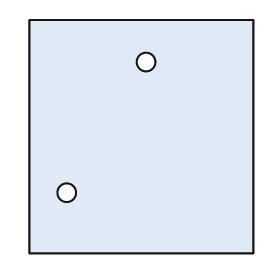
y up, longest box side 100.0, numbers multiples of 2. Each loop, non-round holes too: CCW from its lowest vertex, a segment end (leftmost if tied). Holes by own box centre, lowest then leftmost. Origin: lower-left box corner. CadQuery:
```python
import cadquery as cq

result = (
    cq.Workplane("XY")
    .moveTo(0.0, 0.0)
    .lineTo(96.0, 0.0)
    .lineTo(96.0, 100.0)
    .lineTo(0.0, 100.0)
    .close()
    .moveTo(16.0, 26.0)
    .circle(4.0)
    .moveTo(50.0, 82.0)
    .circle(4.0)
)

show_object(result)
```